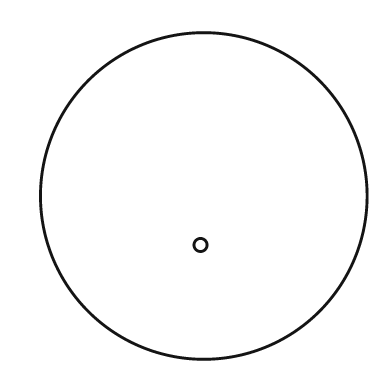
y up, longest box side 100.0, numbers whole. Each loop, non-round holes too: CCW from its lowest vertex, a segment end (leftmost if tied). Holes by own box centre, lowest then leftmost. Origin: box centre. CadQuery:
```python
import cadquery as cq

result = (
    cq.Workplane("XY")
    .moveTo(0.0, 0.0)
    .circle(50.0)
    .moveTo(-1.0, -15.0)
    .circle(2.0)
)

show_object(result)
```